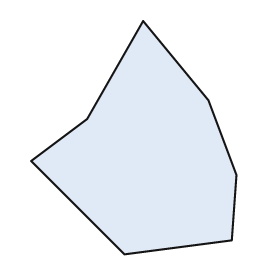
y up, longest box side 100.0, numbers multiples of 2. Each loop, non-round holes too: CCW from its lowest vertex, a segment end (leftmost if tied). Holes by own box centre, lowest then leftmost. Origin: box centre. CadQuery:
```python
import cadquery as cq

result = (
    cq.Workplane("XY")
    .moveTo(-4.0, -50.0)
    .lineTo(42.0, -44.0)
    .lineTo(44.0, -16.0)
    .lineTo(32.0, 16.0)
    .lineTo(4.0, 50.0)
    .lineTo(-20.0, 8.0)
    .lineTo(-44.0, -10.0)
    .close()
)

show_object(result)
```